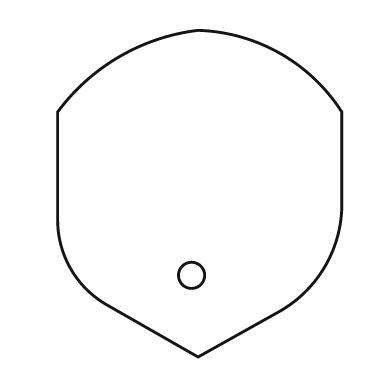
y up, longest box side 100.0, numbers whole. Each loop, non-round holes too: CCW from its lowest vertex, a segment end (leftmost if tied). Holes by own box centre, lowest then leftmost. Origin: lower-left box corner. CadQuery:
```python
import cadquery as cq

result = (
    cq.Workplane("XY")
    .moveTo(43.0, 0.0)
    .lineTo(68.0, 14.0)
    .threePointArc((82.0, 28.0), (87.0, 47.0))
    .lineTo(87.0, 75.0)
    .threePointArc((68.0, 93.0), (43.0, 100.0))
    .threePointArc((19.0, 92.0), (0.0, 75.0))
    .lineTo(0.0, 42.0)
    .threePointArc((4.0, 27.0), (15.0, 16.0))
    .close()
    .moveTo(41.0, 25.0)
    .circle(4.0)
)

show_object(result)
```